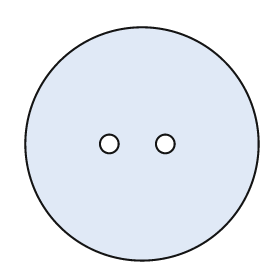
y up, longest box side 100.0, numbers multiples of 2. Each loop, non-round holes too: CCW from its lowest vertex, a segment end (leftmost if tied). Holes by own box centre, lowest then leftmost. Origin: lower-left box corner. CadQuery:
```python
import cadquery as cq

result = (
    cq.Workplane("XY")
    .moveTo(50.0, 50.0)
    .circle(50.0)
    .moveTo(36.0, 50.0)
    .circle(4.0)
    .moveTo(60.0, 50.0)
    .circle(4.0)
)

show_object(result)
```